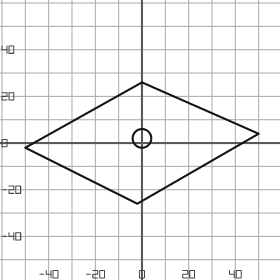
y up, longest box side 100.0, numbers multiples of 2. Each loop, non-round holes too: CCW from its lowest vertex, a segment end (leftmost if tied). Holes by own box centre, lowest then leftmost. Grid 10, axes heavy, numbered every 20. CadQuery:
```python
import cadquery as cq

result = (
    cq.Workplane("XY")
    .moveTo(-2.0, -26.0)
    .lineTo(50.0, 4.0)
    .lineTo(0.0, 26.0)
    .lineTo(-50.0, -2.0)
    .close()
    .moveTo(0.0, 2.0)
    .circle(4.0)
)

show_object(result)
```